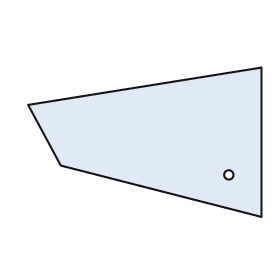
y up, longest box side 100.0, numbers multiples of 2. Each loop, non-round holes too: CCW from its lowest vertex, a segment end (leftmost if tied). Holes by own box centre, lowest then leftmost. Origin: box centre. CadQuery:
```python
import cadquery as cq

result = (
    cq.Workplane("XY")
    .moveTo(50.0, -32.0)
    .lineTo(50.0, 32.0)
    .lineTo(-50.0, 16.0)
    .lineTo(-36.0, -10.0)
    .close()
    .moveTo(36.0, -14.0)
    .circle(2.0)
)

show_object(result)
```